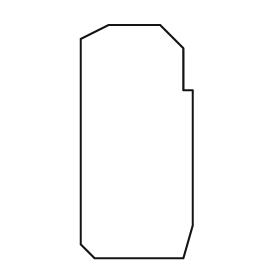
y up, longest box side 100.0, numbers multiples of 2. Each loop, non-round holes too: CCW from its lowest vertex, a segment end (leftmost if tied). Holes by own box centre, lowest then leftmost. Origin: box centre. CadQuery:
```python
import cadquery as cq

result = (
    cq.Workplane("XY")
    .moveTo(-18.0, -50.0)
    .lineTo(20.0, -50.0)
    .lineTo(24.0, -36.0)
    .lineTo(24.0, 22.0)
    .lineTo(20.0, 22.0)
    .lineTo(20.0, 40.0)
    .lineTo(10.0, 50.0)
    .lineTo(-12.0, 50.0)
    .lineTo(-24.0, 44.0)
    .lineTo(-24.0, -44.0)
    .close()
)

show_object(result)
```